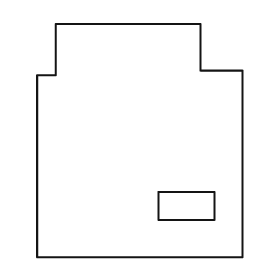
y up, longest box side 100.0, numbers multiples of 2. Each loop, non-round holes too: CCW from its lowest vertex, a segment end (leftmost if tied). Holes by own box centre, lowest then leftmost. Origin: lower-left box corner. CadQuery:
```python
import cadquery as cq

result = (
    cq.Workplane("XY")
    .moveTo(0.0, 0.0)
    .lineTo(88.0, 0.0)
    .lineTo(88.0, 80.0)
    .lineTo(70.0, 80.0)
    .lineTo(70.0, 100.0)
    .lineTo(8.0, 100.0)
    .lineTo(8.0, 78.0)
    .lineTo(0.0, 78.0)
    .close()
    .moveTo(52.0, 16.0)
    .lineTo(76.0, 16.0)
    .lineTo(76.0, 28.0)
    .lineTo(52.0, 28.0)
    .close()
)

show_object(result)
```